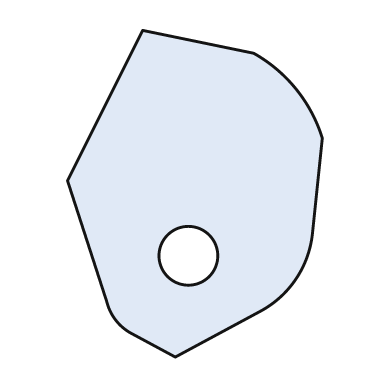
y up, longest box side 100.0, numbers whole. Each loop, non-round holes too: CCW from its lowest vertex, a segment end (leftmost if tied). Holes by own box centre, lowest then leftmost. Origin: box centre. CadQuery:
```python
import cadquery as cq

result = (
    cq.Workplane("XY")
    .moveTo(-6.0, -50.0)
    .lineTo(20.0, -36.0)
    .threePointArc((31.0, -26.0), (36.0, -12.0))
    .lineTo(39.0, 17.0)
    .threePointArc((31.0, 32.0), (18.0, 43.0))
    .lineTo(-16.0, 50.0)
    .lineTo(-39.0, 4.0)
    .lineTo(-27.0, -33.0)
    .threePointArc((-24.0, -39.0), (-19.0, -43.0))
    .close()
    .moveTo(-2.0, -19.0)
    .circle(9.0)
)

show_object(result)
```